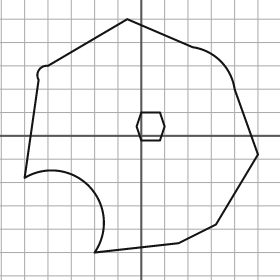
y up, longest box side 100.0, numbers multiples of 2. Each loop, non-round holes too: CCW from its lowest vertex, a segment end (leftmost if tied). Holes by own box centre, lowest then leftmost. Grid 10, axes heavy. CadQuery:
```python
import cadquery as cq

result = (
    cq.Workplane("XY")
    .moveTo(-20.0, -50.0)
    .lineTo(16.0, -46.0)
    .lineTo(32.0, -38.0)
    .lineTo(50.0, -8.0)
    .lineTo(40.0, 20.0)
    .threePointArc((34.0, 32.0), (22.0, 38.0))
    .lineTo(-6.0, 50.0)
    .lineTo(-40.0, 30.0)
    .threePointArc((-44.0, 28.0), (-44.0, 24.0))
    .lineTo(-50.0, -18.0)
    .threePointArc((-22.0, -22.0), (-20.0, -50.0))
    .close()
    .moveTo(0.0, -2.0)
    .lineTo(8.0, -2.0)
    .lineTo(10.0, 4.0)
    .lineTo(8.0, 10.0)
    .lineTo(0.0, 10.0)
    .lineTo(-2.0, 4.0)
    .close()
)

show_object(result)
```